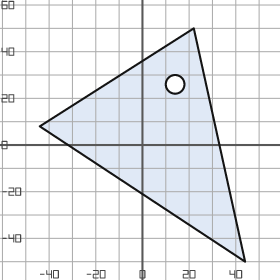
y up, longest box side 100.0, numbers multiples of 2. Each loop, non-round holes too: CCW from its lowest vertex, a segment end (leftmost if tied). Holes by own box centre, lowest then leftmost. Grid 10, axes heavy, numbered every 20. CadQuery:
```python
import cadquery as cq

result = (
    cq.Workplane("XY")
    .moveTo(44.0, -50.0)
    .lineTo(22.0, 50.0)
    .lineTo(-44.0, 8.0)
    .close()
    .moveTo(14.0, 26.0)
    .circle(4.0)
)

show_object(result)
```